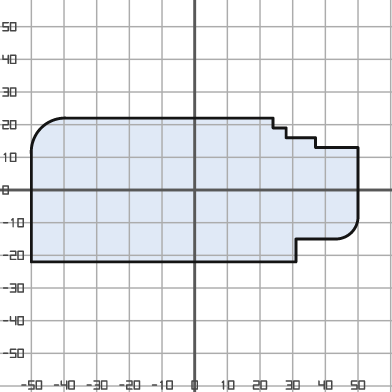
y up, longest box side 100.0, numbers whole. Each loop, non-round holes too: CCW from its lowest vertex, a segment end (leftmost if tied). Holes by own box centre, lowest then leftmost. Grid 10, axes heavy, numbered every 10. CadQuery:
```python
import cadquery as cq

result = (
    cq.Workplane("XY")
    .moveTo(-50.0, -22.0)
    .lineTo(31.0, -22.0)
    .lineTo(31.0, -15.0)
    .lineTo(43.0, -15.0)
    .threePointArc((48.0, -13.0), (50.0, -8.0))
    .lineTo(50.0, 13.0)
    .lineTo(37.0, 13.0)
    .lineTo(37.0, 16.0)
    .lineTo(28.0, 16.0)
    .lineTo(28.0, 19.0)
    .lineTo(24.0, 19.0)
    .lineTo(24.0, 22.0)
    .lineTo(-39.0, 22.0)
    .threePointArc((-47.0, 19.0), (-50.0, 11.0))
    .close()
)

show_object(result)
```